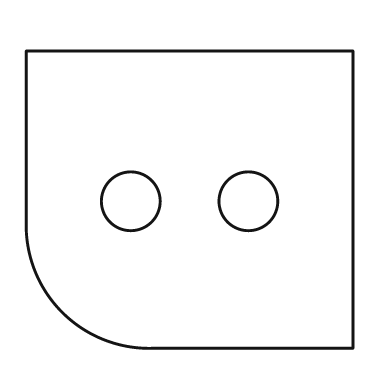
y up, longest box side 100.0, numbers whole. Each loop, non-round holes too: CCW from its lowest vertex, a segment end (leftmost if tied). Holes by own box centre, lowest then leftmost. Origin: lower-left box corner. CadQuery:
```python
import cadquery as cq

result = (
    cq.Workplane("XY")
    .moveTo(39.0, 0.0)
    .lineTo(100.0, 0.0)
    .lineTo(100.0, 91.0)
    .lineTo(0.0, 91.0)
    .lineTo(0.0, 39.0)
    .threePointArc((11.0, 11.0), (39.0, 0.0))
    .close()
    .moveTo(32.0, 45.0)
    .circle(9.0)
    .moveTo(68.0, 45.0)
    .circle(9.0)
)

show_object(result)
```